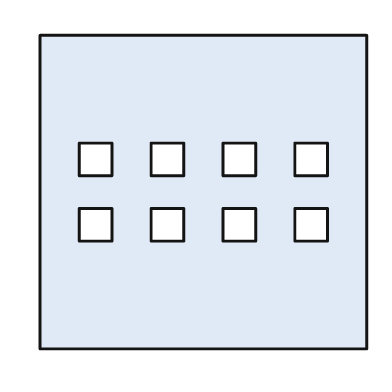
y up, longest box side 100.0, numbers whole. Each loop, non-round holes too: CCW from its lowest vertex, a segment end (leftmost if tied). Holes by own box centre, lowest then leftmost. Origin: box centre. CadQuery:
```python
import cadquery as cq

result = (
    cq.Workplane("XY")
    .moveTo(-50.0, -48.0)
    .lineTo(50.0, -48.0)
    .lineTo(50.0, 48.0)
    .lineTo(-50.0, 48.0)
    .close()
    .moveTo(-38.0, -15.0)
    .lineTo(-28.0, -15.0)
    .lineTo(-28.0, -5.0)
    .lineTo(-38.0, -5.0)
    .close()
    .moveTo(-16.0, -15.0)
    .lineTo(-6.0, -15.0)
    .lineTo(-6.0, -5.0)
    .lineTo(-16.0, -5.0)
    .close()
    .moveTo(6.0, -15.0)
    .lineTo(16.0, -15.0)
    .lineTo(16.0, -5.0)
    .lineTo(6.0, -5.0)
    .close()
    .moveTo(28.0, -15.0)
    .lineTo(38.0, -15.0)
    .lineTo(38.0, -5.0)
    .lineTo(28.0, -5.0)
    .close()
    .moveTo(-38.0, 5.0)
    .lineTo(-28.0, 5.0)
    .lineTo(-28.0, 15.0)
    .lineTo(-38.0, 15.0)
    .close()
    .moveTo(-16.0, 5.0)
    .lineTo(-6.0, 5.0)
    .lineTo(-6.0, 15.0)
    .lineTo(-16.0, 15.0)
    .close()
    .moveTo(6.0, 5.0)
    .lineTo(16.0, 5.0)
    .lineTo(16.0, 15.0)
    .lineTo(6.0, 15.0)
    .close()
    .moveTo(28.0, 5.0)
    .lineTo(38.0, 5.0)
    .lineTo(38.0, 15.0)
    .lineTo(28.0, 15.0)
    .close()
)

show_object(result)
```